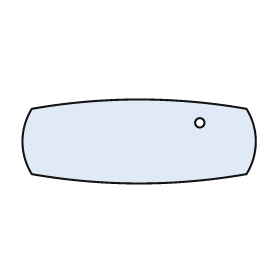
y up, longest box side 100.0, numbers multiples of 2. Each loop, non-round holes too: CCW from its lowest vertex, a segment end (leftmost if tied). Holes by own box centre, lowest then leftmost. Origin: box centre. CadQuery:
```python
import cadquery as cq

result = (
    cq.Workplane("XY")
    .moveTo(-46.0, -14.0)
    .threePointArc((0.0, -18.0), (46.0, -14.0))
    .threePointArc((50.0, 0.0), (46.0, 14.0))
    .threePointArc((0.0, 18.0), (-46.0, 14.0))
    .threePointArc((-50.0, 0.0), (-46.0, -14.0))
    .close()
    .moveTo(26.0, 8.0)
    .circle(2.0)
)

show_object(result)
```